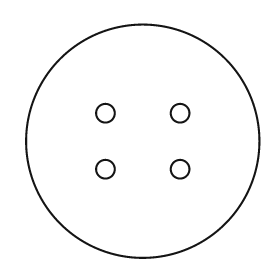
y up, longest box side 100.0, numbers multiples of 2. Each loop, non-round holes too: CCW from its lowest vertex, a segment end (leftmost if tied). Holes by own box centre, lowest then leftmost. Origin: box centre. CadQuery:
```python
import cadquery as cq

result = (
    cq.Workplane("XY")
    .moveTo(0.0, 0.0)
    .circle(50.0)
    .moveTo(-16.0, -12.0)
    .circle(4.0)
    .moveTo(16.0, -12.0)
    .circle(4.0)
    .moveTo(-16.0, 12.0)
    .circle(4.0)
    .moveTo(16.0, 12.0)
    .circle(4.0)
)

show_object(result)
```